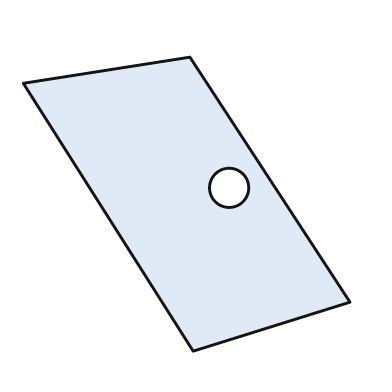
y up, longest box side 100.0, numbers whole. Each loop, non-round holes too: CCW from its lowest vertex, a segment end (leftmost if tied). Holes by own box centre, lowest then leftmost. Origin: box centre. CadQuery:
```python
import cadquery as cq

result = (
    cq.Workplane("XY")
    .moveTo(2.0, -45.0)
    .lineTo(50.0, -30.0)
    .lineTo(1.0, 45.0)
    .lineTo(-50.0, 37.0)
    .close()
    .moveTo(13.0, 5.0)
    .circle(6.0)
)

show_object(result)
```